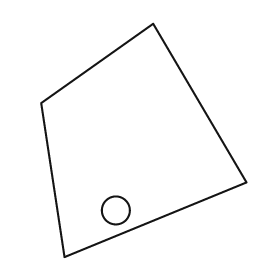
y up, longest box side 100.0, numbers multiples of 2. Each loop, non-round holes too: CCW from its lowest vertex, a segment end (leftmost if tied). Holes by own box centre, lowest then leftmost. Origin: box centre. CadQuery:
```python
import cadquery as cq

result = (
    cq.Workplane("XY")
    .moveTo(-34.0, -50.0)
    .lineTo(44.0, -18.0)
    .lineTo(4.0, 50.0)
    .lineTo(-44.0, 16.0)
    .close()
    .moveTo(-12.0, -30.0)
    .circle(6.0)
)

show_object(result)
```